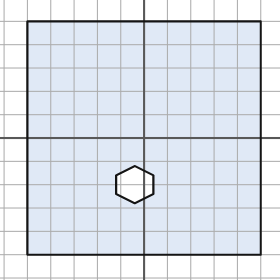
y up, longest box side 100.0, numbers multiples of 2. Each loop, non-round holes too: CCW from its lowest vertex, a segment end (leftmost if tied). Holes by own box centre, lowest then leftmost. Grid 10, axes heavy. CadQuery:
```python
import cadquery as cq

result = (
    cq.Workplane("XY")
    .moveTo(-50.0, -50.0)
    .lineTo(50.0, -50.0)
    .lineTo(50.0, 50.0)
    .lineTo(-50.0, 50.0)
    .close()
    .moveTo(-4.0, -28.0)
    .lineTo(4.0, -24.0)
    .lineTo(4.0, -16.0)
    .lineTo(-4.0, -12.0)
    .lineTo(-12.0, -16.0)
    .lineTo(-12.0, -24.0)
    .close()
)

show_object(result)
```